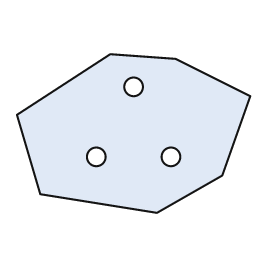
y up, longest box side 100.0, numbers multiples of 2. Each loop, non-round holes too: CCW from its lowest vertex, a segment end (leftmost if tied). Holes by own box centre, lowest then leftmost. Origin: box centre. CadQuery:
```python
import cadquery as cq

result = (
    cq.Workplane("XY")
    .moveTo(10.0, -34.0)
    .lineTo(38.0, -18.0)
    .lineTo(50.0, 16.0)
    .lineTo(18.0, 32.0)
    .lineTo(-10.0, 34.0)
    .lineTo(-50.0, 8.0)
    .lineTo(-40.0, -26.0)
    .close()
    .moveTo(-16.0, -10.0)
    .circle(4.0)
    .moveTo(16.0, -10.0)
    .circle(4.0)
    .moveTo(0.0, 20.0)
    .circle(4.0)
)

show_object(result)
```